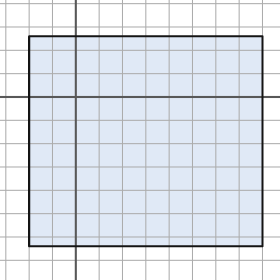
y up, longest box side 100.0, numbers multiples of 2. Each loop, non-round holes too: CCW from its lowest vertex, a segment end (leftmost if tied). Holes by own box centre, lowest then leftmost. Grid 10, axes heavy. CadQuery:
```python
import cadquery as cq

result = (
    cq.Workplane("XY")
    .moveTo(-20.0, -64.0)
    .lineTo(80.0, -64.0)
    .lineTo(80.0, 26.0)
    .lineTo(-20.0, 26.0)
    .close()
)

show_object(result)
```